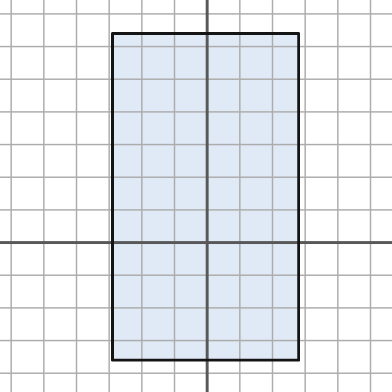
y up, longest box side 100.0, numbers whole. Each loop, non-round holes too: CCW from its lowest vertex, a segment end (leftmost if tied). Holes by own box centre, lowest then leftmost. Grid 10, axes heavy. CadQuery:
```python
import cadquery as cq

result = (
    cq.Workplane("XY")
    .moveTo(-29.0, -36.0)
    .lineTo(28.0, -36.0)
    .lineTo(28.0, 64.0)
    .lineTo(-29.0, 64.0)
    .close()
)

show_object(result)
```